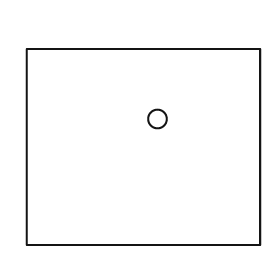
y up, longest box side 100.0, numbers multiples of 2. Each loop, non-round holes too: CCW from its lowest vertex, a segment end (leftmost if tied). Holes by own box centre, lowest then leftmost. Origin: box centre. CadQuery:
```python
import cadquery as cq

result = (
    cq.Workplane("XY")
    .moveTo(-50.0, -42.0)
    .lineTo(50.0, -42.0)
    .lineTo(50.0, 42.0)
    .lineTo(-50.0, 42.0)
    .close()
    .moveTo(6.0, 12.0)
    .circle(4.0)
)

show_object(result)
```